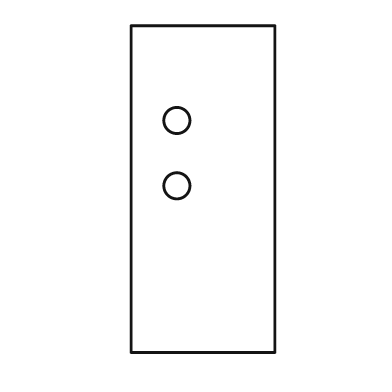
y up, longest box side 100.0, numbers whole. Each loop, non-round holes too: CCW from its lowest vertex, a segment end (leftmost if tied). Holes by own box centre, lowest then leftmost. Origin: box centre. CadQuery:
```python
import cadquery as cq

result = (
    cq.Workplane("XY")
    .moveTo(-22.0, -50.0)
    .lineTo(22.0, -50.0)
    .lineTo(22.0, 50.0)
    .lineTo(-22.0, 50.0)
    .close()
    .moveTo(-8.0, 1.0)
    .circle(4.0)
    .moveTo(-8.0, 21.0)
    .circle(4.0)
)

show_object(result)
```